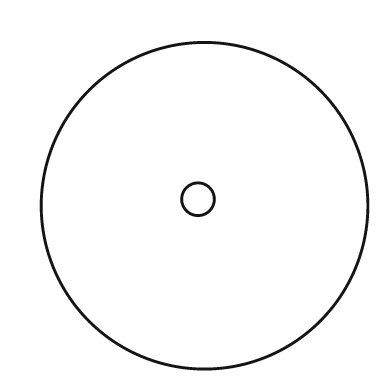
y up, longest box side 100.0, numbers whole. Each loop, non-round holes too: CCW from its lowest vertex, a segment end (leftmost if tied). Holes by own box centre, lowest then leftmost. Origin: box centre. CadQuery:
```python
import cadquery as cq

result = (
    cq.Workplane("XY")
    .moveTo(0.0, 0.0)
    .circle(50.0)
    .moveTo(-2.0, 2.0)
    .circle(5.0)
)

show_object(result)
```